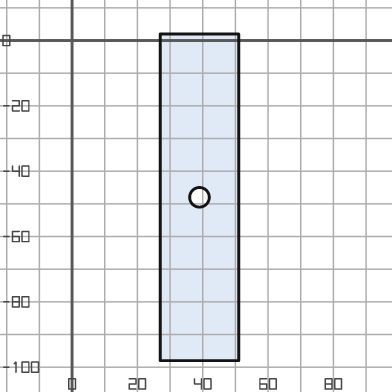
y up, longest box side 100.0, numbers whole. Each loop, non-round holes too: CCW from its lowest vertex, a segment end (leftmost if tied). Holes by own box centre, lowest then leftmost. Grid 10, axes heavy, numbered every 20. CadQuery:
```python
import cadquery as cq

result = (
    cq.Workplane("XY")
    .moveTo(27.0, -98.0)
    .lineTo(51.0, -98.0)
    .lineTo(51.0, 2.0)
    .lineTo(27.0, 2.0)
    .close()
    .moveTo(39.0, -48.0)
    .circle(3.0)
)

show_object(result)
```